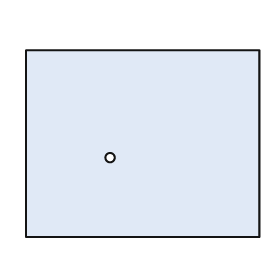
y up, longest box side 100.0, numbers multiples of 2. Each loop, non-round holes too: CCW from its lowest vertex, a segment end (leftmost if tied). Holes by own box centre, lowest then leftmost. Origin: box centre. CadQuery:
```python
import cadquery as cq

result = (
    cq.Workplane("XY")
    .moveTo(-50.0, -40.0)
    .lineTo(50.0, -40.0)
    .lineTo(50.0, 40.0)
    .lineTo(-50.0, 40.0)
    .close()
    .moveTo(-14.0, -6.0)
    .circle(2.0)
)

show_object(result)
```